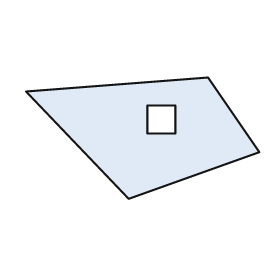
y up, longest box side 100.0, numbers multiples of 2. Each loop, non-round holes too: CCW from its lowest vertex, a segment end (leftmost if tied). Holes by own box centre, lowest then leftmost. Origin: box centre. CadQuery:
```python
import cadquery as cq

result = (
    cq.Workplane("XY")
    .moveTo(-6.0, -26.0)
    .lineTo(50.0, -6.0)
    .lineTo(28.0, 26.0)
    .lineTo(-50.0, 20.0)
    .close()
    .moveTo(2.0, 2.0)
    .lineTo(14.0, 2.0)
    .lineTo(14.0, 14.0)
    .lineTo(2.0, 14.0)
    .close()
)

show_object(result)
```